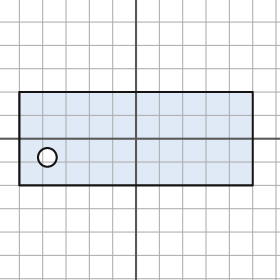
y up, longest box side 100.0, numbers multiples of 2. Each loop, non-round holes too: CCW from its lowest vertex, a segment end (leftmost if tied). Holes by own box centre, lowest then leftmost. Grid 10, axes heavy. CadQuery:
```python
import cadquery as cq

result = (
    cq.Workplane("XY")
    .moveTo(-50.0, -20.0)
    .lineTo(50.0, -20.0)
    .lineTo(50.0, 20.0)
    .lineTo(-50.0, 20.0)
    .close()
    .moveTo(-38.0, -8.0)
    .circle(4.0)
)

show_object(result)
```